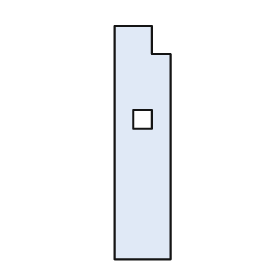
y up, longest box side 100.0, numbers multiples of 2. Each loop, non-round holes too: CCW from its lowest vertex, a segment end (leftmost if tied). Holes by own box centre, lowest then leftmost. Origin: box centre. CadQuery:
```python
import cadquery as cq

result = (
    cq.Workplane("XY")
    .moveTo(-12.0, -50.0)
    .lineTo(12.0, -50.0)
    .lineTo(12.0, 38.0)
    .lineTo(4.0, 38.0)
    .lineTo(4.0, 50.0)
    .lineTo(-12.0, 50.0)
    .close()
    .moveTo(-4.0, 6.0)
    .lineTo(4.0, 6.0)
    .lineTo(4.0, 14.0)
    .lineTo(-4.0, 14.0)
    .close()
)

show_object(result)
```